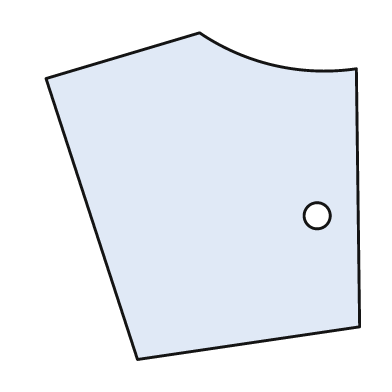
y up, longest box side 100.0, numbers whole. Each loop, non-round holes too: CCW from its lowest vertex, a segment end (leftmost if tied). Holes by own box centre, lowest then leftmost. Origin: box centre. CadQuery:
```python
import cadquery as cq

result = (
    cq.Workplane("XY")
    .moveTo(-20.0, -50.0)
    .lineTo(48.0, -40.0)
    .lineTo(47.0, 39.0)
    .threePointArc((22.0, 40.0), (-1.0, 50.0))
    .lineTo(-48.0, 36.0)
    .close()
    .moveTo(35.0, -6.0)
    .circle(4.0)
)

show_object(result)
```